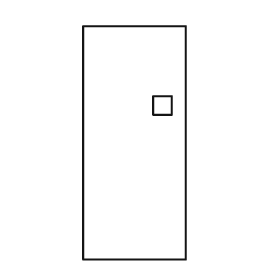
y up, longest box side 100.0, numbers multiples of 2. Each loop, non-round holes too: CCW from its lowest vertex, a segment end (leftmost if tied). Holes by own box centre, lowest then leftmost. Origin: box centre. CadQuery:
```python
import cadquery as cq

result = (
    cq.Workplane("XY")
    .moveTo(-22.0, -50.0)
    .lineTo(22.0, -50.0)
    .lineTo(22.0, 50.0)
    .lineTo(-22.0, 50.0)
    .close()
    .moveTo(8.0, 12.0)
    .lineTo(16.0, 12.0)
    .lineTo(16.0, 20.0)
    .lineTo(8.0, 20.0)
    .close()
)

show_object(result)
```